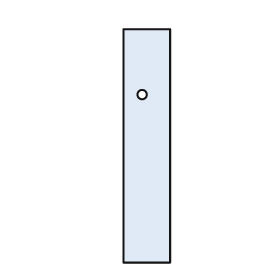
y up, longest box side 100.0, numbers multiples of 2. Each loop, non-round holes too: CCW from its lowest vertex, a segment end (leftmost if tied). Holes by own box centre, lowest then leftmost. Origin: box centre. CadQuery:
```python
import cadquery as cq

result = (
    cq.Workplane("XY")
    .moveTo(-10.0, -50.0)
    .lineTo(10.0, -50.0)
    .lineTo(10.0, 50.0)
    .lineTo(-10.0, 50.0)
    .close()
    .moveTo(-2.0, 22.0)
    .circle(2.0)
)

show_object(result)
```